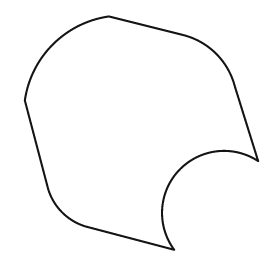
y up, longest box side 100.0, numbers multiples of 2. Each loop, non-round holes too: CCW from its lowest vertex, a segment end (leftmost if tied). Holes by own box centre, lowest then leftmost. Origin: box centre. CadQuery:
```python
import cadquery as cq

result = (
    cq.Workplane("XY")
    .moveTo(14.0, -50.0)
    .threePointArc((16.0, -16.0), (50.0, -12.0))
    .lineTo(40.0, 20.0)
    .threePointArc((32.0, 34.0), (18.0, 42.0))
    .lineTo(-14.0, 50.0)
    .threePointArc((-38.0, 38.0), (-50.0, 14.0))
    .lineTo(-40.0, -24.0)
    .threePointArc((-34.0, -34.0), (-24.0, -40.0))
    .close()
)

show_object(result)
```